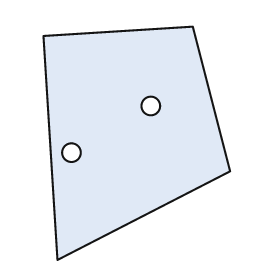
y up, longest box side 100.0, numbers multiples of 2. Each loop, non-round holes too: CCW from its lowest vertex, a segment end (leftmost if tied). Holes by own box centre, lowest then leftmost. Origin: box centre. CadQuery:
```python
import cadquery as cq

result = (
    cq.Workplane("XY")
    .moveTo(-34.0, -50.0)
    .lineTo(40.0, -12.0)
    .lineTo(24.0, 50.0)
    .lineTo(-40.0, 46.0)
    .close()
    .moveTo(-28.0, -4.0)
    .circle(4.0)
    .moveTo(6.0, 16.0)
    .circle(4.0)
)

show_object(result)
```